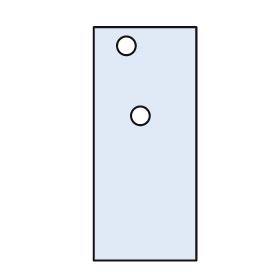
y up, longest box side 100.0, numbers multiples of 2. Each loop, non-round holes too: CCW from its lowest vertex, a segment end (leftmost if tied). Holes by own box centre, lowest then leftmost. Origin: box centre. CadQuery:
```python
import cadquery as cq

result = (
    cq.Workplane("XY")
    .moveTo(-22.0, -50.0)
    .lineTo(22.0, -50.0)
    .lineTo(22.0, 50.0)
    .lineTo(-22.0, 50.0)
    .close()
    .moveTo(-2.0, 12.0)
    .circle(4.0)
    .moveTo(-8.0, 42.0)
    .circle(4.0)
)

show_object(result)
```